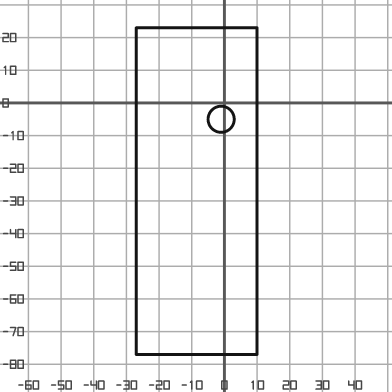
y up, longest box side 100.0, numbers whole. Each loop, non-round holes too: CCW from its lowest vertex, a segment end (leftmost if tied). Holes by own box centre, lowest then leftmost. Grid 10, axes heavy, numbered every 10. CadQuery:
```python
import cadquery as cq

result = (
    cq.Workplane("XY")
    .moveTo(-27.0, -77.0)
    .lineTo(10.0, -77.0)
    .lineTo(10.0, 23.0)
    .lineTo(-27.0, 23.0)
    .close()
    .moveTo(-1.0, -5.0)
    .circle(4.0)
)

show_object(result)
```